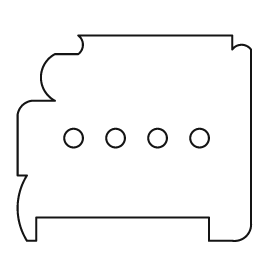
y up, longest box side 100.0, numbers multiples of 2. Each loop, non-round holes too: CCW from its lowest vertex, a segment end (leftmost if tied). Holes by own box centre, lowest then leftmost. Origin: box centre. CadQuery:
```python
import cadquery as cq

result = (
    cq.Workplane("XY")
    .moveTo(-46.0, -44.0)
    .lineTo(-42.0, -44.0)
    .lineTo(-42.0, -34.0)
    .lineTo(32.0, -34.0)
    .lineTo(32.0, -44.0)
    .lineTo(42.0, -44.0)
    .threePointArc((48.0, -42.0), (50.0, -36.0))
    .lineTo(50.0, 38.0)
    .threePointArc((46.0, 40.0), (42.0, 38.0))
    .lineTo(42.0, 44.0)
    .lineTo(-24.0, 44.0)
    .threePointArc((-22.0, 40.0), (-24.0, 36.0))
    .lineTo(-34.0, 36.0)
    .threePointArc((-40.0, 26.0), (-34.0, 16.0))
    .lineTo(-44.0, 16.0)
    .threePointArc((-48.0, 14.0), (-50.0, 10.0))
    .lineTo(-50.0, -16.0)
    .lineTo(-46.0, -16.0)
    .threePointArc((-50.0, -30.0), (-46.0, -44.0))
    .close()
    .moveTo(-26.0, 0.0)
    .circle(4.0)
    .moveTo(-8.0, 0.0)
    .circle(4.0)
    .moveTo(10.0, 0.0)
    .circle(4.0)
    .moveTo(28.0, 0.0)
    .circle(4.0)
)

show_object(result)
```